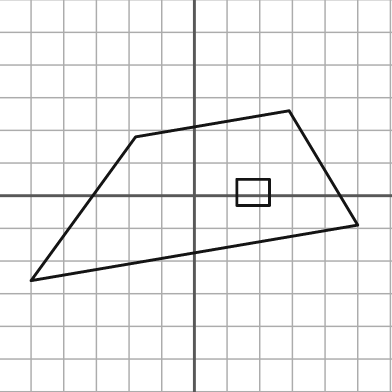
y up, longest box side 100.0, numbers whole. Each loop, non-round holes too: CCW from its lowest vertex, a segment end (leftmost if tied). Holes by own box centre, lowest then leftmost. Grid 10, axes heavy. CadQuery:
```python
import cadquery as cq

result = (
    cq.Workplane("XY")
    .moveTo(-50.0, -26.0)
    .lineTo(50.0, -9.0)
    .lineTo(29.0, 26.0)
    .lineTo(-18.0, 18.0)
    .close()
    .moveTo(13.0, -3.0)
    .lineTo(23.0, -3.0)
    .lineTo(23.0, 5.0)
    .lineTo(13.0, 5.0)
    .close()
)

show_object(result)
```